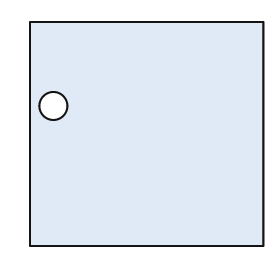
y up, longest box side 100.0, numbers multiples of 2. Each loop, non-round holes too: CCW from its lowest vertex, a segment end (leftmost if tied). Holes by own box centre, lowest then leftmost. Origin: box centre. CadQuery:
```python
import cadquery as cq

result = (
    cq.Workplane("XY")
    .moveTo(-50.0, -48.0)
    .lineTo(50.0, -48.0)
    .lineTo(50.0, 48.0)
    .lineTo(-50.0, 48.0)
    .close()
    .moveTo(-40.0, 12.0)
    .circle(6.0)
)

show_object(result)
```